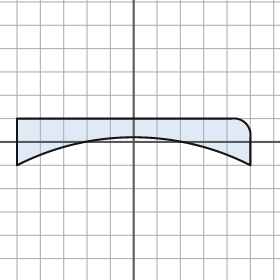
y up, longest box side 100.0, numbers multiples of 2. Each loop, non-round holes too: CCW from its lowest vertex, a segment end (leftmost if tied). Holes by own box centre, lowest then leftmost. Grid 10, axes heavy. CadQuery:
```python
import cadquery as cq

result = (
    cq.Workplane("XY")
    .moveTo(-50.0, -10.0)
    .threePointArc((0.0, 2.0), (50.0, -10.0))
    .lineTo(50.0, 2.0)
    .threePointArc((48.0, 8.0), (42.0, 10.0))
    .lineTo(-50.0, 10.0)
    .close()
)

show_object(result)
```